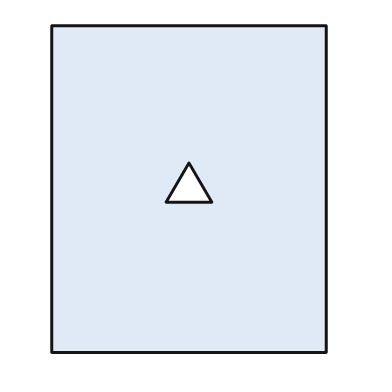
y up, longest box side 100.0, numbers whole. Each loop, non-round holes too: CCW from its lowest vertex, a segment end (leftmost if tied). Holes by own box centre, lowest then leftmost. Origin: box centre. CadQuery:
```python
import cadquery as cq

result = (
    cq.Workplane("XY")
    .moveTo(-42.0, -50.0)
    .lineTo(42.0, -50.0)
    .lineTo(42.0, 50.0)
    .lineTo(-42.0, 50.0)
    .close()
    .moveTo(-7.0, -4.0)
    .lineTo(7.0, -4.0)
    .lineTo(0.0, 8.0)
    .close()
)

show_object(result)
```